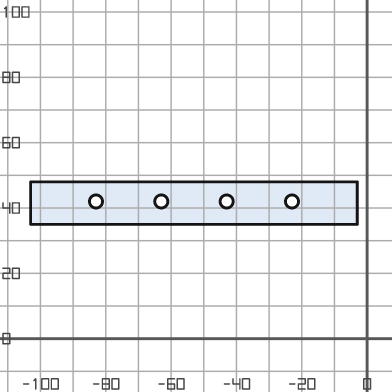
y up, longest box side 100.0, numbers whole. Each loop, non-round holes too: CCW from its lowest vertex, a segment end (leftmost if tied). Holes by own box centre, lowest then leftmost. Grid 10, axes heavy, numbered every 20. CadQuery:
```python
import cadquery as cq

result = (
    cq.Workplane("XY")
    .moveTo(-103.0, 35.0)
    .lineTo(-3.0, 35.0)
    .lineTo(-3.0, 48.0)
    .lineTo(-103.0, 48.0)
    .close()
    .moveTo(-83.0, 42.0)
    .circle(2.0)
    .moveTo(-63.0, 42.0)
    .circle(2.0)
    .moveTo(-43.0, 42.0)
    .circle(2.0)
    .moveTo(-23.0, 42.0)
    .circle(2.0)
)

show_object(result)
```